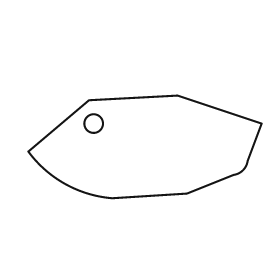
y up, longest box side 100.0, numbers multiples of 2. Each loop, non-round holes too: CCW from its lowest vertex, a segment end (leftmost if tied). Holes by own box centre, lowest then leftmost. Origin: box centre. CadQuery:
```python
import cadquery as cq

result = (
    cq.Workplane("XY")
    .moveTo(-14.0, -22.0)
    .lineTo(18.0, -20.0)
    .lineTo(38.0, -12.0)
    .threePointArc((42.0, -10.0), (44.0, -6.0))
    .lineTo(50.0, 10.0)
    .lineTo(14.0, 22.0)
    .lineTo(-24.0, 20.0)
    .lineTo(-50.0, -2.0)
    .threePointArc((-34.0, -16.0), (-14.0, -22.0))
    .close()
    .moveTo(-22.0, 10.0)
    .circle(4.0)
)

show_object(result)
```